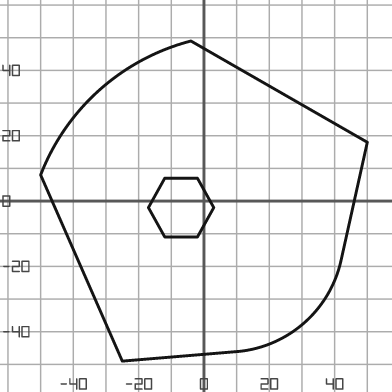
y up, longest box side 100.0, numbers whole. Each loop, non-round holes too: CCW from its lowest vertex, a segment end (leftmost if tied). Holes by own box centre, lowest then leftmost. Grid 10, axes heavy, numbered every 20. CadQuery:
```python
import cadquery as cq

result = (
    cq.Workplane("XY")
    .moveTo(-25.0, -49.0)
    .lineTo(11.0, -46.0)
    .threePointArc((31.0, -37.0), (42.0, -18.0))
    .lineTo(50.0, 18.0)
    .lineTo(-4.0, 49.0)
    .threePointArc((-32.0, 34.0), (-50.0, 8.0))
    .close()
    .moveTo(-12.0, -11.0)
    .lineTo(-2.0, -11.0)
    .lineTo(3.0, -2.0)
    .lineTo(-2.0, 7.0)
    .lineTo(-12.0, 7.0)
    .lineTo(-17.0, -2.0)
    .close()
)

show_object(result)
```